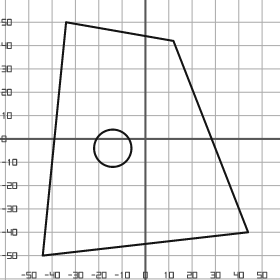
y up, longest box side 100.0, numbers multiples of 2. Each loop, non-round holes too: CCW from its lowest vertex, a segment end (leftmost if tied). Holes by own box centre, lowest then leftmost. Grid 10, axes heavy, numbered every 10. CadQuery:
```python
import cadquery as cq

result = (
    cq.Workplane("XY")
    .moveTo(-44.0, -50.0)
    .lineTo(44.0, -40.0)
    .lineTo(12.0, 42.0)
    .lineTo(-34.0, 50.0)
    .close()
    .moveTo(-14.0, -4.0)
    .circle(8.0)
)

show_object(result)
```